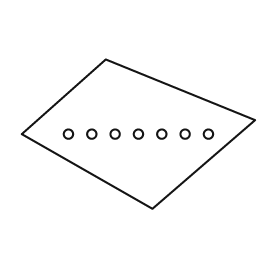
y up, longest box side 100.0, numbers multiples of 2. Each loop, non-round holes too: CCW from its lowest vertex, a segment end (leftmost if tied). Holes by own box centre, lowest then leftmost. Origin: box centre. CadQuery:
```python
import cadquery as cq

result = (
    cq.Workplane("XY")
    .moveTo(6.0, -32.0)
    .lineTo(50.0, 6.0)
    .lineTo(-14.0, 32.0)
    .lineTo(-50.0, 0.0)
    .close()
    .moveTo(-30.0, 0.0)
    .circle(2.0)
    .moveTo(-20.0, 0.0)
    .circle(2.0)
    .moveTo(-10.0, 0.0)
    .circle(2.0)
    .moveTo(0.0, 0.0)
    .circle(2.0)
    .moveTo(10.0, 0.0)
    .circle(2.0)
    .moveTo(20.0, 0.0)
    .circle(2.0)
    .moveTo(30.0, 0.0)
    .circle(2.0)
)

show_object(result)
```